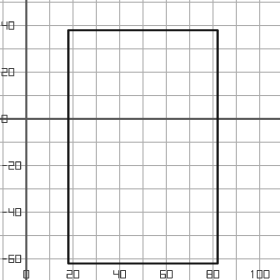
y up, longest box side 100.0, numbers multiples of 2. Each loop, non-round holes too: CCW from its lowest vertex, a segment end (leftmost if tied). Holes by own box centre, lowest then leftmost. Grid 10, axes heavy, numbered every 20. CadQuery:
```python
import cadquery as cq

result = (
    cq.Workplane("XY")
    .moveTo(18.0, -62.0)
    .lineTo(82.0, -62.0)
    .lineTo(82.0, 38.0)
    .lineTo(18.0, 38.0)
    .close()
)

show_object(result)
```